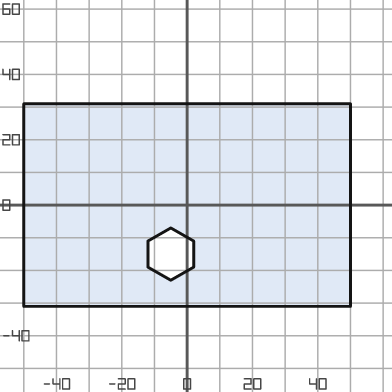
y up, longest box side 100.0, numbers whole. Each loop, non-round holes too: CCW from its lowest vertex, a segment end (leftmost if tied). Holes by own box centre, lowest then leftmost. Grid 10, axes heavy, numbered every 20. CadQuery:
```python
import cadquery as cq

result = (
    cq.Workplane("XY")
    .moveTo(-50.0, -31.0)
    .lineTo(50.0, -31.0)
    .lineTo(50.0, 31.0)
    .lineTo(-50.0, 31.0)
    .close()
    .moveTo(-5.0, -23.0)
    .lineTo(2.0, -19.0)
    .lineTo(2.0, -11.0)
    .lineTo(-5.0, -7.0)
    .lineTo(-12.0, -11.0)
    .lineTo(-12.0, -19.0)
    .close()
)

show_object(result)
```